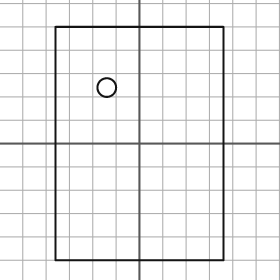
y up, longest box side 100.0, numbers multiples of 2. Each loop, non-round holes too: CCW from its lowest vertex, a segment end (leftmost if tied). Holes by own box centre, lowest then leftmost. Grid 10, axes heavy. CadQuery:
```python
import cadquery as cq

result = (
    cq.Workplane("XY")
    .moveTo(-36.0, -50.0)
    .lineTo(36.0, -50.0)
    .lineTo(36.0, 50.0)
    .lineTo(-36.0, 50.0)
    .close()
    .moveTo(-14.0, 24.0)
    .circle(4.0)
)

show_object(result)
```